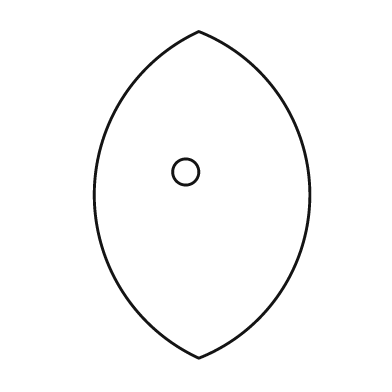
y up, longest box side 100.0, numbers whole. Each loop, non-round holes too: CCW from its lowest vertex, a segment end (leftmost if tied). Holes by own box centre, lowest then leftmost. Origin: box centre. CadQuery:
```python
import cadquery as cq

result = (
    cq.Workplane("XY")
    .moveTo(-1.0, -50.0)
    .threePointArc((33.0, 0.0), (-1.0, 50.0))
    .threePointArc((-33.0, 0.0), (-1.0, -50.0))
    .close()
    .moveTo(-5.0, 7.0)
    .circle(4.0)
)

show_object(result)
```